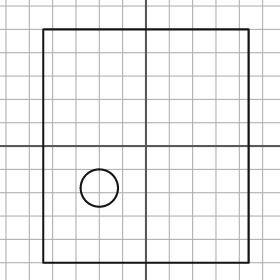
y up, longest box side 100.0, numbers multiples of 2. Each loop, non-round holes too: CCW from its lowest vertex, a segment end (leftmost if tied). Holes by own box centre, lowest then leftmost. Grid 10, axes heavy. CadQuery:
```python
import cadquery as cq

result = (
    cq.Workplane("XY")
    .moveTo(-44.0, -50.0)
    .lineTo(44.0, -50.0)
    .lineTo(44.0, 50.0)
    .lineTo(-44.0, 50.0)
    .close()
    .moveTo(-20.0, -18.0)
    .circle(8.0)
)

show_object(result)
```